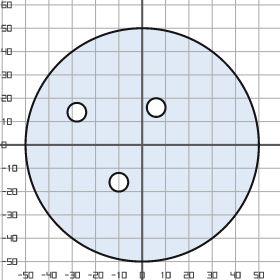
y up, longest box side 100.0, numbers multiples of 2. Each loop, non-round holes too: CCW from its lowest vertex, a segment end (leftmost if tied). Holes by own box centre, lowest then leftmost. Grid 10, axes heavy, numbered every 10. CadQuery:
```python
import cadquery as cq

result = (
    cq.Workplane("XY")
    .moveTo(0.0, 0.0)
    .circle(50.0)
    .moveTo(-10.0, -16.0)
    .circle(4.0)
    .moveTo(-28.0, 14.0)
    .circle(4.0)
    .moveTo(6.0, 16.0)
    .circle(4.0)
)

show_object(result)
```